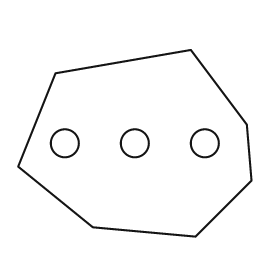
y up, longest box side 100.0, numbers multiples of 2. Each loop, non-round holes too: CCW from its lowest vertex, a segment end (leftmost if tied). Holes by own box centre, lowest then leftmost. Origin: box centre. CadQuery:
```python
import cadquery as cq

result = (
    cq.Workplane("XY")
    .moveTo(26.0, -40.0)
    .lineTo(50.0, -16.0)
    .lineTo(48.0, 8.0)
    .lineTo(24.0, 40.0)
    .lineTo(-34.0, 30.0)
    .lineTo(-50.0, -10.0)
    .lineTo(-18.0, -36.0)
    .close()
    .moveTo(-30.0, 0.0)
    .circle(6.0)
    .moveTo(0.0, 0.0)
    .circle(6.0)
    .moveTo(30.0, 0.0)
    .circle(6.0)
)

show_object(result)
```